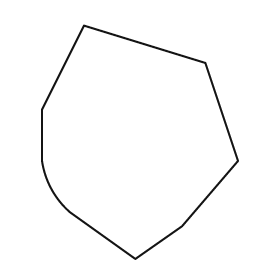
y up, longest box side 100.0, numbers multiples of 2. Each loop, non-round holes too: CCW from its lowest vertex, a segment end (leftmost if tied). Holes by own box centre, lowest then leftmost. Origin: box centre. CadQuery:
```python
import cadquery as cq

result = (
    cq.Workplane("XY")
    .moveTo(-2.0, -50.0)
    .lineTo(18.0, -36.0)
    .lineTo(42.0, -8.0)
    .lineTo(28.0, 34.0)
    .lineTo(-24.0, 50.0)
    .lineTo(-42.0, 14.0)
    .lineTo(-42.0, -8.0)
    .threePointArc((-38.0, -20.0), (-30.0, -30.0))
    .close()
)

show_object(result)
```